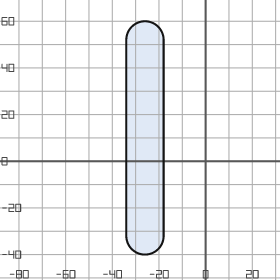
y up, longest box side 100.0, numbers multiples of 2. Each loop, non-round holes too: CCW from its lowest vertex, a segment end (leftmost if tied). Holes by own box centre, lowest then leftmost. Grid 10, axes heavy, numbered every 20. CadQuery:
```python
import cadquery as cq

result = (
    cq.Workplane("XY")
    .moveTo(-34.0, -32.0)
    .threePointArc((-26.0, -40.0), (-18.0, -32.0))
    .lineTo(-18.0, 52.0)
    .threePointArc((-26.0, 60.0), (-34.0, 52.0))
    .close()
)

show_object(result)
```